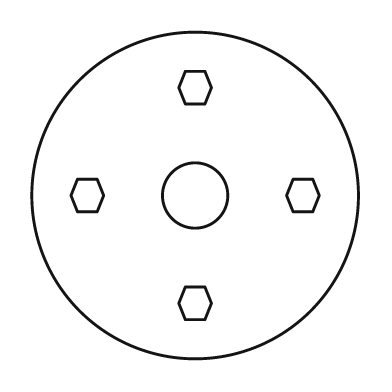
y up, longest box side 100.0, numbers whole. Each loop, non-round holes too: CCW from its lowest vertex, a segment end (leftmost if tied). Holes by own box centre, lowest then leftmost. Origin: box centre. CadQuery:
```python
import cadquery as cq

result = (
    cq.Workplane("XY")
    .moveTo(0.0, 0.0)
    .circle(50.0)
    .moveTo(-3.0, -38.0)
    .lineTo(3.0, -38.0)
    .lineTo(5.0, -33.0)
    .lineTo(3.0, -28.0)
    .lineTo(-3.0, -28.0)
    .lineTo(-5.0, -33.0)
    .close()
    .moveTo(-36.0, -5.0)
    .lineTo(-30.0, -5.0)
    .lineTo(-28.0, 0.0)
    .lineTo(-30.0, 5.0)
    .lineTo(-36.0, 5.0)
    .lineTo(-38.0, 0.0)
    .close()
    .moveTo(0.0, 0.0)
    .circle(10.0)
    .moveTo(30.0, -5.0)
    .lineTo(36.0, -5.0)
    .lineTo(38.0, 0.0)
    .lineTo(36.0, 5.0)
    .lineTo(30.0, 5.0)
    .lineTo(28.0, 0.0)
    .close()
    .moveTo(-3.0, 28.0)
    .lineTo(3.0, 28.0)
    .lineTo(5.0, 33.0)
    .lineTo(3.0, 38.0)
    .lineTo(-3.0, 38.0)
    .lineTo(-5.0, 33.0)
    .close()
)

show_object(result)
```